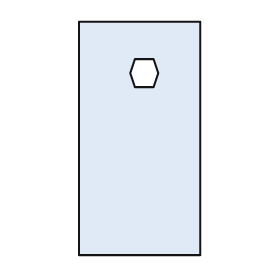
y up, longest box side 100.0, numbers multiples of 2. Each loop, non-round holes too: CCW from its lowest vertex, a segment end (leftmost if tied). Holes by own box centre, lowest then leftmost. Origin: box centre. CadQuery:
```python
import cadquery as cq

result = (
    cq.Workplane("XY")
    .moveTo(-26.0, -50.0)
    .lineTo(26.0, -50.0)
    .lineTo(26.0, 50.0)
    .lineTo(-26.0, 50.0)
    .close()
    .moveTo(-2.0, 22.0)
    .lineTo(6.0, 22.0)
    .lineTo(8.0, 28.0)
    .lineTo(6.0, 34.0)
    .lineTo(-2.0, 34.0)
    .lineTo(-4.0, 28.0)
    .close()
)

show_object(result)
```